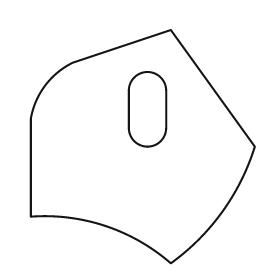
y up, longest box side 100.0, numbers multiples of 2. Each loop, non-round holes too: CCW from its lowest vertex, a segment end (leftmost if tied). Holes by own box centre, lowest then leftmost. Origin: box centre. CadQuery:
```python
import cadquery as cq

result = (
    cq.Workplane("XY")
    .moveTo(12.0, -50.0)
    .threePointArc((34.0, -28.0), (48.0, 0.0))
    .lineTo(12.0, 50.0)
    .lineTo(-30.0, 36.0)
    .threePointArc((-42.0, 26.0), (-48.0, 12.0))
    .lineTo(-48.0, -30.0)
    .threePointArc((-16.0, -34.0), (12.0, -50.0))
    .close()
    .moveTo(-6.0, 8.0)
    .threePointArc((2.0, 0.0), (10.0, 8.0))
    .lineTo(10.0, 24.0)
    .threePointArc((2.0, 32.0), (-6.0, 24.0))
    .close()
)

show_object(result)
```